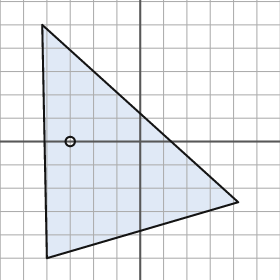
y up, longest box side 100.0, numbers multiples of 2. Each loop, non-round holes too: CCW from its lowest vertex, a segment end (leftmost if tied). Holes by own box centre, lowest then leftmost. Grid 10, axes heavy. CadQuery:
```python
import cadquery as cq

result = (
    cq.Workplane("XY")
    .moveTo(-40.0, -50.0)
    .lineTo(42.0, -26.0)
    .lineTo(-42.0, 50.0)
    .close()
    .moveTo(-30.0, 0.0)
    .circle(2.0)
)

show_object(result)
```